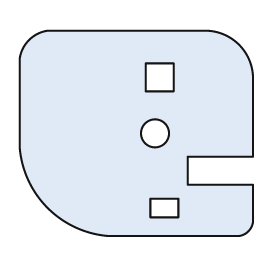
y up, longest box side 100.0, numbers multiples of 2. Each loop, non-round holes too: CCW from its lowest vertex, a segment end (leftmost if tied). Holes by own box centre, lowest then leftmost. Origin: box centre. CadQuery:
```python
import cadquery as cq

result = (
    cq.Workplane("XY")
    .moveTo(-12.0, -44.0)
    .lineTo(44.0, -44.0)
    .threePointArc((48.0, -42.0), (50.0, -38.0))
    .lineTo(50.0, -22.0)
    .lineTo(22.0, -22.0)
    .lineTo(22.0, -10.0)
    .lineTo(50.0, -10.0)
    .lineTo(50.0, 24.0)
    .threePointArc((44.0, 38.0), (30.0, 44.0))
    .lineTo(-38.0, 44.0)
    .threePointArc((-46.0, 40.0), (-50.0, 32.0))
    .lineTo(-50.0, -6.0)
    .threePointArc((-38.0, -32.0), (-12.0, -44.0))
    .close()
    .moveTo(6.0, -36.0)
    .lineTo(18.0, -36.0)
    .lineTo(18.0, -28.0)
    .lineTo(6.0, -28.0)
    .close()
    .moveTo(8.0, 0.0)
    .circle(6.0)
    .moveTo(4.0, 18.0)
    .lineTo(16.0, 18.0)
    .lineTo(16.0, 30.0)
    .lineTo(4.0, 30.0)
    .close()
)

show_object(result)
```